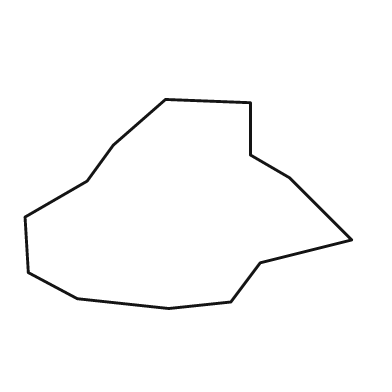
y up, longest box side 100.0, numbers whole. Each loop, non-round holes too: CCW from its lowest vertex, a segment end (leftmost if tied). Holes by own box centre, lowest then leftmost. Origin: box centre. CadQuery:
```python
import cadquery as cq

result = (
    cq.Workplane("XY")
    .moveTo(-6.0, -32.0)
    .lineTo(13.0, -30.0)
    .lineTo(22.0, -18.0)
    .lineTo(50.0, -11.0)
    .lineTo(31.0, 8.0)
    .lineTo(19.0, 15.0)
    .lineTo(19.0, 31.0)
    .lineTo(-7.0, 32.0)
    .lineTo(-23.0, 18.0)
    .lineTo(-31.0, 7.0)
    .lineTo(-50.0, -4.0)
    .lineTo(-49.0, -21.0)
    .lineTo(-34.0, -29.0)
    .close()
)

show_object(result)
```